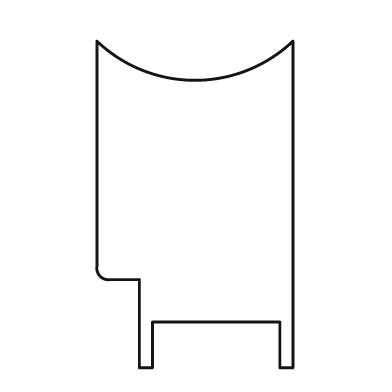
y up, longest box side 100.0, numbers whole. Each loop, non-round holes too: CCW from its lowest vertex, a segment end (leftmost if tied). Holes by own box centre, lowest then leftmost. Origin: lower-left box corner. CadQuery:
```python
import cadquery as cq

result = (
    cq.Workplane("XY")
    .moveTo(13.0, 0.0)
    .lineTo(17.0, 0.0)
    .lineTo(17.0, 14.0)
    .lineTo(56.0, 14.0)
    .lineTo(56.0, 0.0)
    .lineTo(60.0, 0.0)
    .lineTo(60.0, 100.0)
    .threePointArc((30.0, 88.0), (0.0, 100.0))
    .lineTo(0.0, 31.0)
    .threePointArc((1.0, 28.0), (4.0, 27.0))
    .lineTo(13.0, 27.0)
    .close()
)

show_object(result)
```